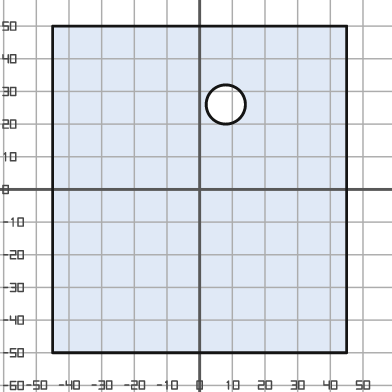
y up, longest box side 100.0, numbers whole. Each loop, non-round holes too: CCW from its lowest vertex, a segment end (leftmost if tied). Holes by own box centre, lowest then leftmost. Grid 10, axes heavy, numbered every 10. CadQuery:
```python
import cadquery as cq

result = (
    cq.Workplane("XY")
    .moveTo(-45.0, -50.0)
    .lineTo(45.0, -50.0)
    .lineTo(45.0, 50.0)
    .lineTo(-45.0, 50.0)
    .close()
    .moveTo(8.0, 26.0)
    .circle(6.0)
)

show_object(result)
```